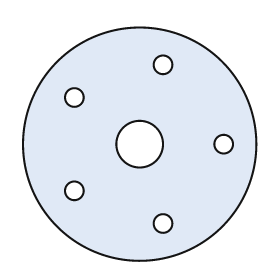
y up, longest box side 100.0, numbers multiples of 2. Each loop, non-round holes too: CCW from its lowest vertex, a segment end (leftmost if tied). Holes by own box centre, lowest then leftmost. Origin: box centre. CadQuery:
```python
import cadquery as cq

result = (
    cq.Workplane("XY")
    .moveTo(0.0, 0.0)
    .circle(50.0)
    .moveTo(10.0, -34.0)
    .circle(4.0)
    .moveTo(-28.0, -20.0)
    .circle(4.0)
    .moveTo(0.0, 0.0)
    .circle(10.0)
    .moveTo(36.0, 0.0)
    .circle(4.0)
    .moveTo(-28.0, 20.0)
    .circle(4.0)
    .moveTo(10.0, 34.0)
    .circle(4.0)
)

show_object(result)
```